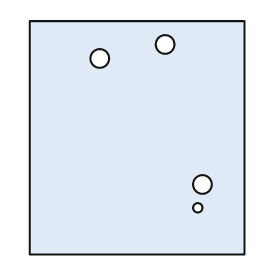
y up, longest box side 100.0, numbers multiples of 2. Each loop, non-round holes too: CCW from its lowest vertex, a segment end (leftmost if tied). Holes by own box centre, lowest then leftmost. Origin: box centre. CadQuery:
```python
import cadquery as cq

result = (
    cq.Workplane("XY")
    .moveTo(-46.0, -50.0)
    .lineTo(46.0, -50.0)
    .lineTo(46.0, 50.0)
    .lineTo(-46.0, 50.0)
    .close()
    .moveTo(26.0, -30.0)
    .circle(2.0)
    .moveTo(28.0, -20.0)
    .circle(4.0)
    .moveTo(-16.0, 34.0)
    .circle(4.0)
    .moveTo(12.0, 40.0)
    .circle(4.0)
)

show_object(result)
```